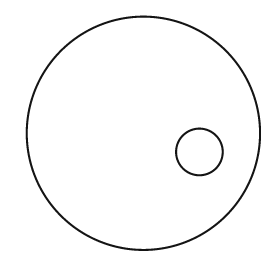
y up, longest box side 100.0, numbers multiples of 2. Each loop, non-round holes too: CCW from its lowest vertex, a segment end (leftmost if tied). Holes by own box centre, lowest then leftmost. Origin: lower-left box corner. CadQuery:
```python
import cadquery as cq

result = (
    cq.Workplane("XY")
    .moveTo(50.0, 50.0)
    .circle(50.0)
    .moveTo(74.0, 42.0)
    .circle(10.0)
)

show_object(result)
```